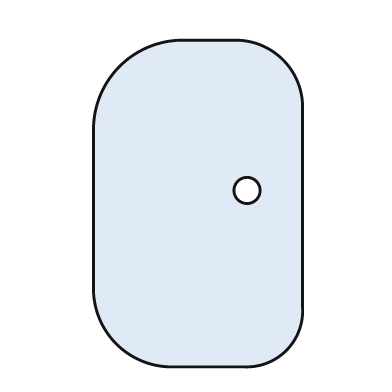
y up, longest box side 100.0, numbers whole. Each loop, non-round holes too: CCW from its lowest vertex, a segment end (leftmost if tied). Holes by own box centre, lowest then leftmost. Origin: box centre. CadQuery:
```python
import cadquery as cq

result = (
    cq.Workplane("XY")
    .moveTo(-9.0, -50.0)
    .lineTo(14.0, -50.0)
    .threePointArc((27.0, -45.0), (32.0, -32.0))
    .lineTo(32.0, 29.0)
    .threePointArc((26.0, 44.0), (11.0, 50.0))
    .lineTo(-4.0, 50.0)
    .threePointArc((-24.0, 42.0), (-32.0, 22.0))
    .lineTo(-32.0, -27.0)
    .threePointArc((-25.0, -43.0), (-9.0, -50.0))
    .close()
    .moveTo(15.0, 4.0)
    .circle(4.0)
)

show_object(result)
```